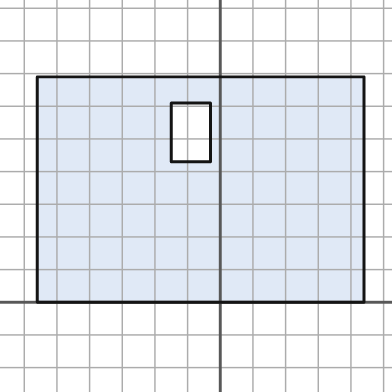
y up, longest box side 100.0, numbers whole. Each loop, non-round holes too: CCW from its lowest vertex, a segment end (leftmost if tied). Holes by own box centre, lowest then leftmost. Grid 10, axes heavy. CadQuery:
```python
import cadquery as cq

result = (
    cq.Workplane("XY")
    .moveTo(-56.0, 0.0)
    .lineTo(44.0, 0.0)
    .lineTo(44.0, 69.0)
    .lineTo(-56.0, 69.0)
    .close()
    .moveTo(-15.0, 43.0)
    .lineTo(-3.0, 43.0)
    .lineTo(-3.0, 61.0)
    .lineTo(-15.0, 61.0)
    .close()
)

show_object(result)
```